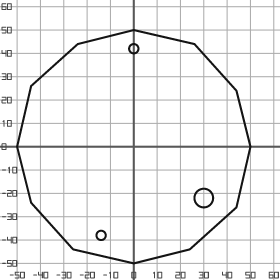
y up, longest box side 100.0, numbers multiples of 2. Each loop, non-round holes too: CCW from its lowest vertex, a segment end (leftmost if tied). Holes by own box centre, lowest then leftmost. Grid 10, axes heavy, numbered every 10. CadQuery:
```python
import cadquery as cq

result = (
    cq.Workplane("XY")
    .moveTo(0.0, -50.0)
    .lineTo(24.0, -44.0)
    .lineTo(44.0, -26.0)
    .lineTo(50.0, 0.0)
    .lineTo(44.0, 24.0)
    .lineTo(26.0, 44.0)
    .lineTo(0.0, 50.0)
    .lineTo(-24.0, 44.0)
    .lineTo(-44.0, 26.0)
    .lineTo(-50.0, 0.0)
    .lineTo(-44.0, -24.0)
    .lineTo(-26.0, -44.0)
    .close()
    .moveTo(-14.0, -38.0)
    .circle(2.0)
    .moveTo(30.0, -22.0)
    .circle(4.0)
    .moveTo(0.0, 42.0)
    .circle(2.0)
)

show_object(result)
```